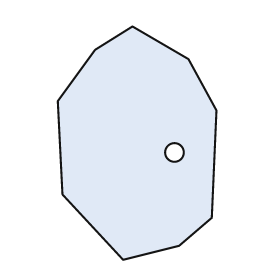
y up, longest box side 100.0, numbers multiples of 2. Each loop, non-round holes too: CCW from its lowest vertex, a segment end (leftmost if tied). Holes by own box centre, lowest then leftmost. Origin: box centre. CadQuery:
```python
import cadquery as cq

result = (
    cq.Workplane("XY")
    .moveTo(-6.0, -50.0)
    .lineTo(18.0, -44.0)
    .lineTo(32.0, -32.0)
    .lineTo(34.0, 14.0)
    .lineTo(22.0, 36.0)
    .lineTo(-2.0, 50.0)
    .lineTo(-18.0, 40.0)
    .lineTo(-34.0, 18.0)
    .lineTo(-32.0, -22.0)
    .close()
    .moveTo(16.0, -4.0)
    .circle(4.0)
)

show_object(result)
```